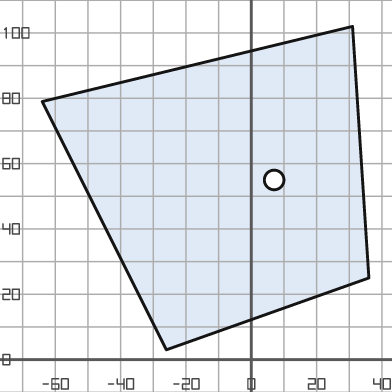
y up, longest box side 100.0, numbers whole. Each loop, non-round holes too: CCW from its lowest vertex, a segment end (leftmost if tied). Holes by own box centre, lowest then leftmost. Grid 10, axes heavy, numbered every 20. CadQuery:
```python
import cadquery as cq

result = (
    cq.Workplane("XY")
    .moveTo(-26.0, 3.0)
    .lineTo(36.0, 25.0)
    .lineTo(31.0, 102.0)
    .lineTo(-64.0, 79.0)
    .close()
    .moveTo(7.0, 55.0)
    .circle(3.0)
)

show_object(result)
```